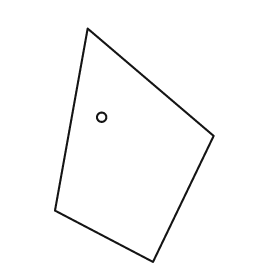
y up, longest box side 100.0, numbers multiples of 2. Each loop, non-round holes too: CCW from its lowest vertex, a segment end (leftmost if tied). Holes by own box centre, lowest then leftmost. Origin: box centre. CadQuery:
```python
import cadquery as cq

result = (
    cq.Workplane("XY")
    .moveTo(8.0, -50.0)
    .lineTo(34.0, 4.0)
    .lineTo(-20.0, 50.0)
    .lineTo(-34.0, -28.0)
    .close()
    .moveTo(-14.0, 12.0)
    .circle(2.0)
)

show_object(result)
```